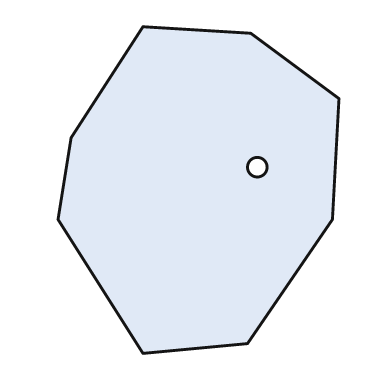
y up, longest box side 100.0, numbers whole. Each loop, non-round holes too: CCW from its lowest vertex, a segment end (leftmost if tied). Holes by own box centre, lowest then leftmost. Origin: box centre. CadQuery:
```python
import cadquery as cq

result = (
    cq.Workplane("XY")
    .moveTo(-17.0, -50.0)
    .lineTo(15.0, -47.0)
    .lineTo(41.0, -9.0)
    .lineTo(43.0, 28.0)
    .lineTo(16.0, 48.0)
    .lineTo(-17.0, 50.0)
    .lineTo(-39.0, 16.0)
    .lineTo(-43.0, -9.0)
    .close()
    .moveTo(18.0, 7.0)
    .circle(3.0)
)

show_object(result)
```